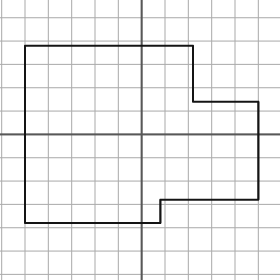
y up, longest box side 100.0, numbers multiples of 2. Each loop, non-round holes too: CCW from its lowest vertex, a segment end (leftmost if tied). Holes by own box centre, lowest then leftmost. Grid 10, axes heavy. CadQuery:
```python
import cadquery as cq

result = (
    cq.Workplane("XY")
    .moveTo(-50.0, -38.0)
    .lineTo(8.0, -38.0)
    .lineTo(8.0, -28.0)
    .lineTo(50.0, -28.0)
    .lineTo(50.0, 14.0)
    .lineTo(22.0, 14.0)
    .lineTo(22.0, 38.0)
    .lineTo(-50.0, 38.0)
    .close()
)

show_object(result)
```